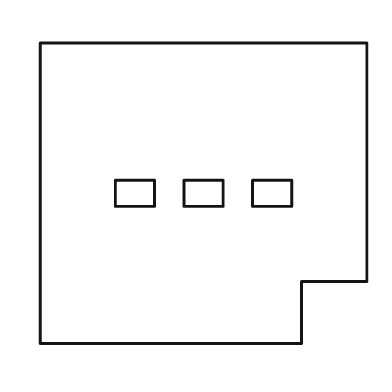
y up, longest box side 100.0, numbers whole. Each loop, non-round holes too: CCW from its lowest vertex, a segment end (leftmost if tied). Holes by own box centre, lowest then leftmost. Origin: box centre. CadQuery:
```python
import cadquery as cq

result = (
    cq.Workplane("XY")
    .moveTo(-50.0, -46.0)
    .lineTo(30.0, -46.0)
    .lineTo(30.0, -27.0)
    .lineTo(50.0, -27.0)
    .lineTo(50.0, 46.0)
    .lineTo(-50.0, 46.0)
    .close()
    .moveTo(-27.0, -4.0)
    .lineTo(-15.0, -4.0)
    .lineTo(-15.0, 4.0)
    .lineTo(-27.0, 4.0)
    .close()
    .moveTo(-6.0, -4.0)
    .lineTo(6.0, -4.0)
    .lineTo(6.0, 4.0)
    .lineTo(-6.0, 4.0)
    .close()
    .moveTo(15.0, -4.0)
    .lineTo(27.0, -4.0)
    .lineTo(27.0, 4.0)
    .lineTo(15.0, 4.0)
    .close()
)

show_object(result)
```